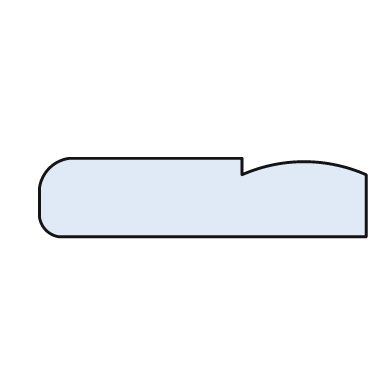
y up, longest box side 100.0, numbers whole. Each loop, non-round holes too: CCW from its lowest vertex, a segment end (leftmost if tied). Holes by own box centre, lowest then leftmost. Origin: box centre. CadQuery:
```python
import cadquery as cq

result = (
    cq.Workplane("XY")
    .moveTo(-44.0, -12.0)
    .lineTo(50.0, -12.0)
    .lineTo(50.0, 7.0)
    .threePointArc((31.0, 11.0), (12.0, 7.0))
    .lineTo(12.0, 12.0)
    .lineTo(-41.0, 12.0)
    .threePointArc((-47.0, 9.0), (-50.0, 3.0))
    .lineTo(-50.0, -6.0)
    .threePointArc((-48.0, -10.0), (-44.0, -12.0))
    .close()
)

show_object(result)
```